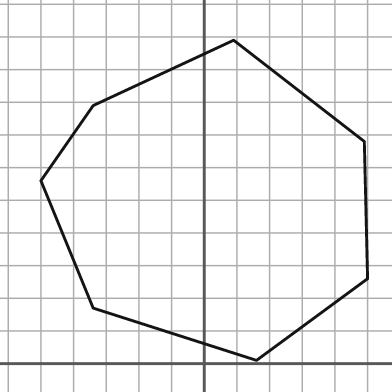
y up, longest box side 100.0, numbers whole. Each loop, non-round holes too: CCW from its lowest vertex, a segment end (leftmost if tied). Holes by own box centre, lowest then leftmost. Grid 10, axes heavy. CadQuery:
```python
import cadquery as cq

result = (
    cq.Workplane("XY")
    .moveTo(16.0, 1.0)
    .lineTo(50.0, 26.0)
    .lineTo(49.0, 68.0)
    .lineTo(9.0, 99.0)
    .lineTo(-34.0, 79.0)
    .lineTo(-50.0, 56.0)
    .lineTo(-34.0, 17.0)
    .close()
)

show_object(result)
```